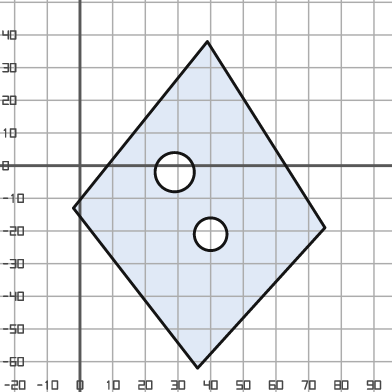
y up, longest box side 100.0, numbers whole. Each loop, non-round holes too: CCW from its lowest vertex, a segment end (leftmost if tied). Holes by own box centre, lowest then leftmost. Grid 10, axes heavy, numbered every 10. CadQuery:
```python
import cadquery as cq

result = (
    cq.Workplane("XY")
    .moveTo(36.0, -62.0)
    .lineTo(75.0, -19.0)
    .lineTo(39.0, 38.0)
    .lineTo(-2.0, -13.0)
    .close()
    .moveTo(40.0, -21.0)
    .circle(5.0)
    .moveTo(29.0, -2.0)
    .circle(6.0)
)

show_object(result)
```